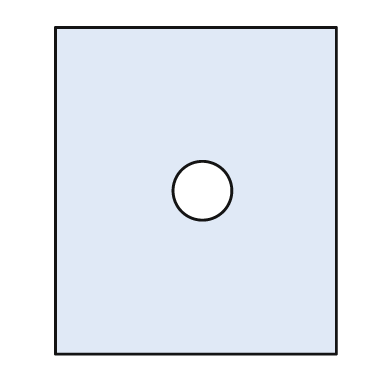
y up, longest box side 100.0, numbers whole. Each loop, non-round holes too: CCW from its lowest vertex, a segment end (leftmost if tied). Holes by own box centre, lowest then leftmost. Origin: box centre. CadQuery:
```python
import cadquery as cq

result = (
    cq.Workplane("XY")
    .moveTo(-43.0, -50.0)
    .lineTo(43.0, -50.0)
    .lineTo(43.0, 50.0)
    .lineTo(-43.0, 50.0)
    .close()
    .moveTo(2.0, 0.0)
    .circle(9.0)
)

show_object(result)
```